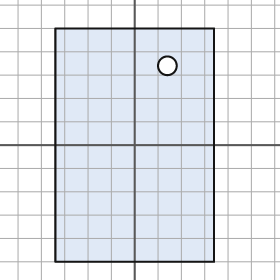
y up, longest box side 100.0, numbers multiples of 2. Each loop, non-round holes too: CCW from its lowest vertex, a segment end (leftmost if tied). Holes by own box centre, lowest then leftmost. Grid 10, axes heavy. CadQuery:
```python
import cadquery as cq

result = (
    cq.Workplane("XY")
    .moveTo(-34.0, -50.0)
    .lineTo(34.0, -50.0)
    .lineTo(34.0, 50.0)
    .lineTo(-34.0, 50.0)
    .close()
    .moveTo(14.0, 34.0)
    .circle(4.0)
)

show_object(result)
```